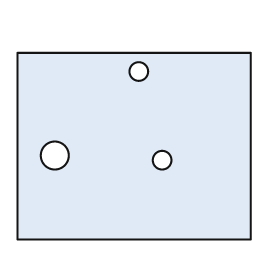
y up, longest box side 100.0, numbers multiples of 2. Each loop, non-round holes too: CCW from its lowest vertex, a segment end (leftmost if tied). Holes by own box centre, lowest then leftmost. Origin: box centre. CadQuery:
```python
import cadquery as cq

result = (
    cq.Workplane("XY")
    .moveTo(-50.0, -40.0)
    .lineTo(50.0, -40.0)
    .lineTo(50.0, 40.0)
    .lineTo(-50.0, 40.0)
    .close()
    .moveTo(12.0, -6.0)
    .circle(4.0)
    .moveTo(-34.0, -4.0)
    .circle(6.0)
    .moveTo(2.0, 32.0)
    .circle(4.0)
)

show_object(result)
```